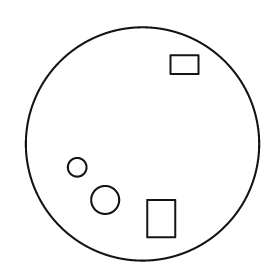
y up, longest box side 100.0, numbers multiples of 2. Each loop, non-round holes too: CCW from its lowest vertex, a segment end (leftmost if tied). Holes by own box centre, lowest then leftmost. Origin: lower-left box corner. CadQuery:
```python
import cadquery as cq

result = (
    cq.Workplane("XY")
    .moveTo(50.0, 50.0)
    .circle(50.0)
    .moveTo(52.0, 10.0)
    .lineTo(64.0, 10.0)
    .lineTo(64.0, 26.0)
    .lineTo(52.0, 26.0)
    .close()
    .moveTo(34.0, 26.0)
    .circle(6.0)
    .moveTo(22.0, 40.0)
    .circle(4.0)
    .moveTo(62.0, 80.0)
    .lineTo(74.0, 80.0)
    .lineTo(74.0, 88.0)
    .lineTo(62.0, 88.0)
    .close()
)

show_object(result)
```